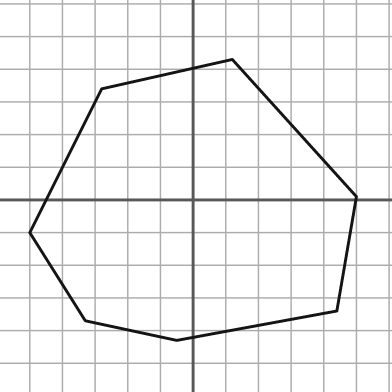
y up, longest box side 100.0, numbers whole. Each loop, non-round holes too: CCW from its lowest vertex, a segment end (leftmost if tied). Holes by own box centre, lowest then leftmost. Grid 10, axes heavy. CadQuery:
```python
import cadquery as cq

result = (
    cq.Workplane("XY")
    .moveTo(-5.0, -43.0)
    .lineTo(44.0, -34.0)
    .lineTo(50.0, 1.0)
    .lineTo(12.0, 43.0)
    .lineTo(-28.0, 34.0)
    .lineTo(-50.0, -10.0)
    .lineTo(-33.0, -37.0)
    .close()
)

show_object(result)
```